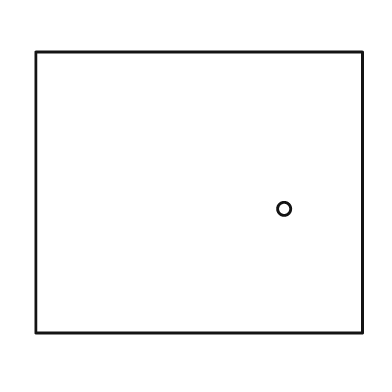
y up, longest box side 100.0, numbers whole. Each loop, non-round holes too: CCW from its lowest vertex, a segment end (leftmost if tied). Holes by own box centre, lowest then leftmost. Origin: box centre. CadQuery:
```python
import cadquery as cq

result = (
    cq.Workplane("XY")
    .moveTo(-50.0, -43.0)
    .lineTo(50.0, -43.0)
    .lineTo(50.0, 43.0)
    .lineTo(-50.0, 43.0)
    .close()
    .moveTo(26.0, -5.0)
    .circle(2.0)
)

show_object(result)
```